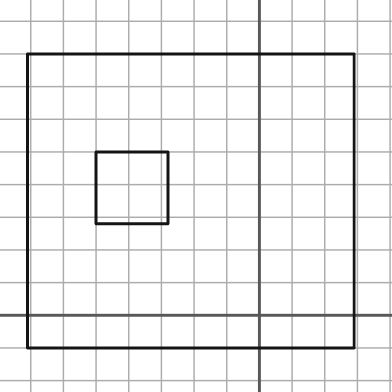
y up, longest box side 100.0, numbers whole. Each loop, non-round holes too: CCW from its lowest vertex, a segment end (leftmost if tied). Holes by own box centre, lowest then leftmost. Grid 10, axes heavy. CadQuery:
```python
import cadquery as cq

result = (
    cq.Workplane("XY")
    .moveTo(-71.0, -10.0)
    .lineTo(29.0, -10.0)
    .lineTo(29.0, 80.0)
    .lineTo(-71.0, 80.0)
    .close()
    .moveTo(-50.0, 28.0)
    .lineTo(-28.0, 28.0)
    .lineTo(-28.0, 50.0)
    .lineTo(-50.0, 50.0)
    .close()
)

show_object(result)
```